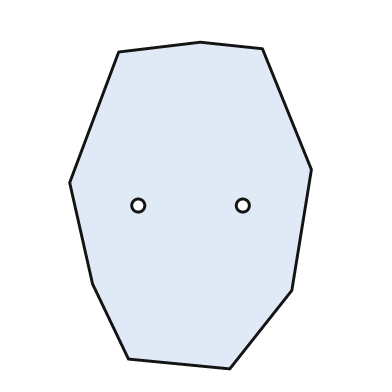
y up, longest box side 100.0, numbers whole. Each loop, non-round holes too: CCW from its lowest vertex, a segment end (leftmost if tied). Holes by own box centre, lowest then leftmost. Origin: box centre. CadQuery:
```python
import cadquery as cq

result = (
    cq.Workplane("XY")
    .moveTo(12.0, -50.0)
    .lineTo(31.0, -26.0)
    .lineTo(37.0, 11.0)
    .lineTo(22.0, 48.0)
    .lineTo(3.0, 50.0)
    .lineTo(-22.0, 47.0)
    .lineTo(-37.0, 7.0)
    .lineTo(-30.0, -24.0)
    .lineTo(-19.0, -47.0)
    .close()
    .moveTo(-16.0, 0.0)
    .circle(2.0)
    .moveTo(16.0, 0.0)
    .circle(2.0)
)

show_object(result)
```